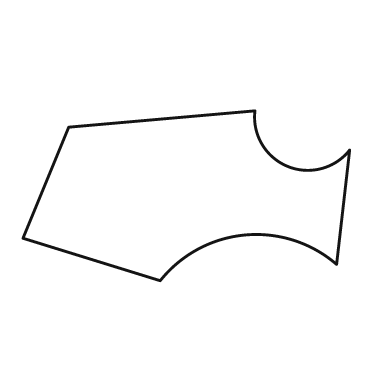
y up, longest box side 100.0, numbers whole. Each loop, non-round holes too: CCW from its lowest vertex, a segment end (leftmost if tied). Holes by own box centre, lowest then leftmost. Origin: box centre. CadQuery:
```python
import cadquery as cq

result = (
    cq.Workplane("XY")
    .moveTo(-8.0, -26.0)
    .threePointArc((18.0, -12.0), (46.0, -21.0))
    .lineTo(50.0, 14.0)
    .threePointArc((31.0, 9.0), (21.0, 26.0))
    .lineTo(-36.0, 21.0)
    .lineTo(-50.0, -13.0)
    .close()
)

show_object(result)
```